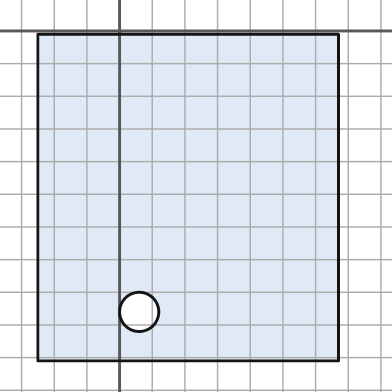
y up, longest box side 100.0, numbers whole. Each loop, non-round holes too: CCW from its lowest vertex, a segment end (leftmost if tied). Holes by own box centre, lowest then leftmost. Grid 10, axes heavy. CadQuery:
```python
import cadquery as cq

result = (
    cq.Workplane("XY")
    .moveTo(-25.0, -101.0)
    .lineTo(67.0, -101.0)
    .lineTo(67.0, -1.0)
    .lineTo(-25.0, -1.0)
    .close()
    .moveTo(6.0, -86.0)
    .circle(6.0)
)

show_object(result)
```